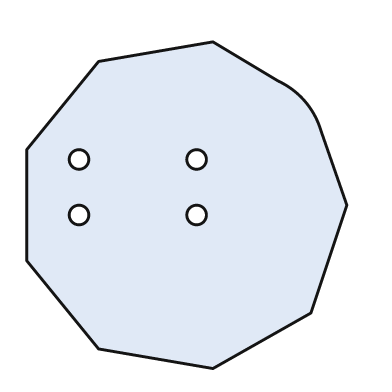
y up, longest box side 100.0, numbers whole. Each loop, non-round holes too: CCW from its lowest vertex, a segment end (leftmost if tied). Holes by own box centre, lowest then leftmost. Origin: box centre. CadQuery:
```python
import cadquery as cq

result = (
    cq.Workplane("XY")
    .moveTo(8.0, -50.0)
    .lineTo(38.0, -33.0)
    .lineTo(49.0, 0.0)
    .lineTo(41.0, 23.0)
    .threePointArc((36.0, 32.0), (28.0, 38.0))
    .lineTo(8.0, 50.0)
    .lineTo(-27.0, 44.0)
    .lineTo(-49.0, 17.0)
    .lineTo(-49.0, -17.0)
    .lineTo(-27.0, -44.0)
    .close()
    .moveTo(-33.0, -3.0)
    .circle(3.0)
    .moveTo(3.0, -3.0)
    .circle(3.0)
    .moveTo(-33.0, 14.0)
    .circle(3.0)
    .moveTo(3.0, 14.0)
    .circle(3.0)
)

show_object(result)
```